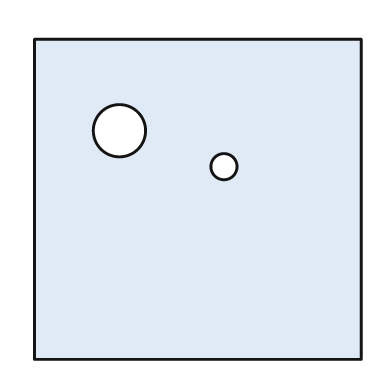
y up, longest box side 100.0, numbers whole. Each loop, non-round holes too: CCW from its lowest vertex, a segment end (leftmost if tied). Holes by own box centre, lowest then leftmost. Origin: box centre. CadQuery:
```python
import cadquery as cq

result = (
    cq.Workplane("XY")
    .moveTo(-50.0, -49.0)
    .lineTo(50.0, -49.0)
    .lineTo(50.0, 49.0)
    .lineTo(-50.0, 49.0)
    .close()
    .moveTo(8.0, 10.0)
    .circle(4.0)
    .moveTo(-24.0, 21.0)
    .circle(8.0)
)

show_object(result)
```